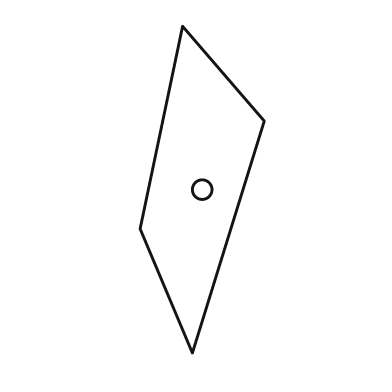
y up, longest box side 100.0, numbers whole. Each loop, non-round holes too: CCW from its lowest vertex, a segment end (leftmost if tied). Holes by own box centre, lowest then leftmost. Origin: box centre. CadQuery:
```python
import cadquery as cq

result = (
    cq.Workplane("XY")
    .moveTo(-3.0, -50.0)
    .lineTo(19.0, 21.0)
    .lineTo(-6.0, 50.0)
    .lineTo(-19.0, -12.0)
    .close()
    .moveTo(0.0, 0.0)
    .circle(3.0)
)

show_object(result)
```